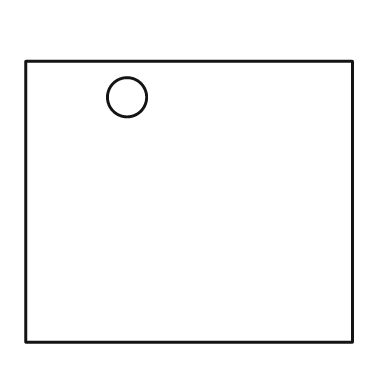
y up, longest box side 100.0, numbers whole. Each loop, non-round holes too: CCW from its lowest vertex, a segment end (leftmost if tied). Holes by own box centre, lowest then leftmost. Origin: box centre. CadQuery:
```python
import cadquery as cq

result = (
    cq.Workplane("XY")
    .moveTo(-50.0, -43.0)
    .lineTo(50.0, -43.0)
    .lineTo(50.0, 43.0)
    .lineTo(-50.0, 43.0)
    .close()
    .moveTo(-19.0, 32.0)
    .circle(6.0)
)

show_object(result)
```